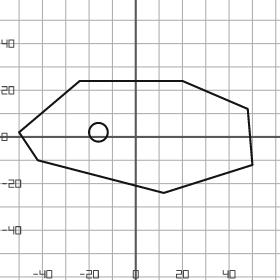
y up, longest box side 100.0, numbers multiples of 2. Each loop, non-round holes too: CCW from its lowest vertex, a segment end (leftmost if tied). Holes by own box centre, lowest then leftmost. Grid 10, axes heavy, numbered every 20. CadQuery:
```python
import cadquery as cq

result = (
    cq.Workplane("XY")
    .moveTo(12.0, -24.0)
    .lineTo(50.0, -12.0)
    .lineTo(48.0, 12.0)
    .lineTo(20.0, 24.0)
    .lineTo(-24.0, 24.0)
    .lineTo(-50.0, 2.0)
    .lineTo(-42.0, -10.0)
    .close()
    .moveTo(-16.0, 2.0)
    .circle(4.0)
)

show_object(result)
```